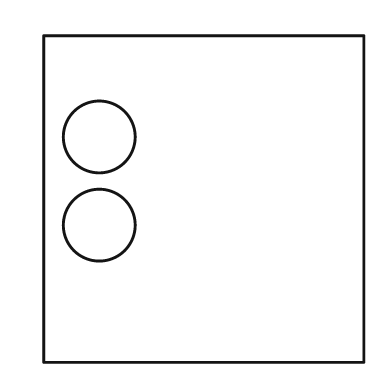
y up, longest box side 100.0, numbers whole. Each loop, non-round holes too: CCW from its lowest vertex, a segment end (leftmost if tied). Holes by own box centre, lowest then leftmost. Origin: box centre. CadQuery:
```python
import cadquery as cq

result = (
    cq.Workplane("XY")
    .moveTo(-49.0, -50.0)
    .lineTo(49.0, -50.0)
    .lineTo(49.0, 50.0)
    .lineTo(-49.0, 50.0)
    .close()
    .moveTo(-32.0, -8.0)
    .circle(11.0)
    .moveTo(-32.0, 19.0)
    .circle(11.0)
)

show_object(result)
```